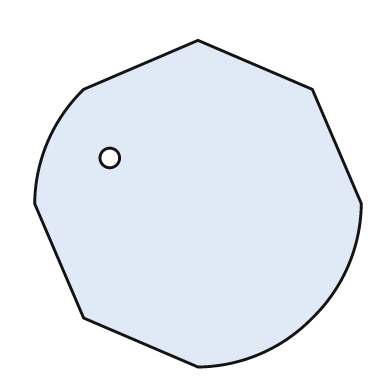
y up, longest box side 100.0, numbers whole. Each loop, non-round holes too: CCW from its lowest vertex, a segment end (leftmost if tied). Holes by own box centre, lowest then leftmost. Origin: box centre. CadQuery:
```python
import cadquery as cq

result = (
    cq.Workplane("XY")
    .moveTo(0.0, -50.0)
    .threePointArc((19.0, -46.0), (35.0, -35.0))
    .threePointArc((46.0, -19.0), (50.0, 0.0))
    .lineTo(35.0, 35.0)
    .lineTo(0.0, 50.0)
    .lineTo(-35.0, 35.0)
    .threePointArc((-46.0, 19.0), (-50.0, 0.0))
    .lineTo(-35.0, -35.0)
    .close()
    .moveTo(-27.0, 14.0)
    .circle(3.0)
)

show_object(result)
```